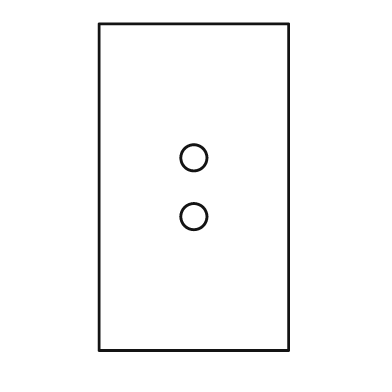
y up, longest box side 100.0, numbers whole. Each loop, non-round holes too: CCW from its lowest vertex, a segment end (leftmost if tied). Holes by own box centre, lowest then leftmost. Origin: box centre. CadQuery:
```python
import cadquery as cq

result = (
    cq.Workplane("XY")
    .moveTo(-29.0, -50.0)
    .lineTo(29.0, -50.0)
    .lineTo(29.0, 50.0)
    .lineTo(-29.0, 50.0)
    .close()
    .moveTo(0.0, -9.0)
    .circle(4.0)
    .moveTo(0.0, 9.0)
    .circle(4.0)
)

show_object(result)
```